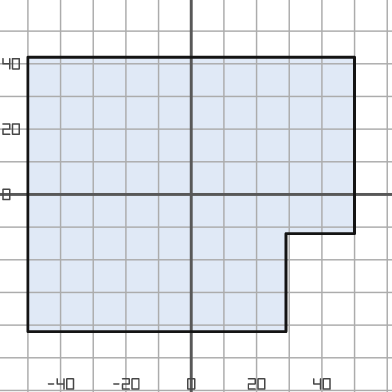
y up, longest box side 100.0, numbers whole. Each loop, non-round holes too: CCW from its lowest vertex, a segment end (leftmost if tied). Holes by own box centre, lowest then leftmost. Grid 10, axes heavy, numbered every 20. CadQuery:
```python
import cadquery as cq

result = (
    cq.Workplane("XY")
    .moveTo(-50.0, -42.0)
    .lineTo(29.0, -42.0)
    .lineTo(29.0, -12.0)
    .lineTo(50.0, -12.0)
    .lineTo(50.0, 42.0)
    .lineTo(-50.0, 42.0)
    .close()
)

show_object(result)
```